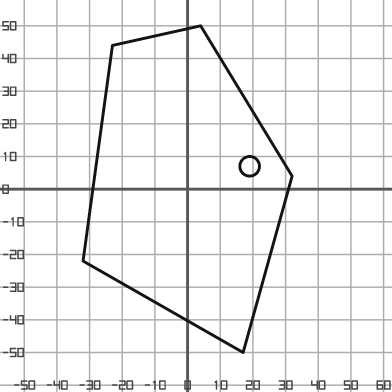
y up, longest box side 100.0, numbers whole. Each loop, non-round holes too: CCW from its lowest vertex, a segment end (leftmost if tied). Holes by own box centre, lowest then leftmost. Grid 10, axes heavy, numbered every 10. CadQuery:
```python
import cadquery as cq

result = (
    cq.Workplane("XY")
    .moveTo(17.0, -50.0)
    .lineTo(32.0, 4.0)
    .lineTo(4.0, 50.0)
    .lineTo(-23.0, 44.0)
    .lineTo(-32.0, -22.0)
    .close()
    .moveTo(19.0, 7.0)
    .circle(3.0)
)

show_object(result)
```